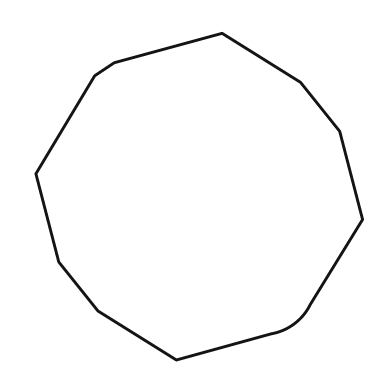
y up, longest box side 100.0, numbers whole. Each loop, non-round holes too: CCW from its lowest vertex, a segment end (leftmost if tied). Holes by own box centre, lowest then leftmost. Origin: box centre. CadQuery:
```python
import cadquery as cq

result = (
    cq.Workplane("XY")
    .moveTo(-7.0, -50.0)
    .lineTo(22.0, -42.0)
    .threePointArc((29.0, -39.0), (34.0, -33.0))
    .lineTo(50.0, -7.0)
    .lineTo(43.0, 20.0)
    .lineTo(31.0, 35.0)
    .lineTo(7.0, 50.0)
    .lineTo(-26.0, 41.0)
    .lineTo(-32.0, 37.0)
    .lineTo(-50.0, 7.0)
    .lineTo(-43.0, -20.0)
    .lineTo(-31.0, -35.0)
    .close()
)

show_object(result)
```